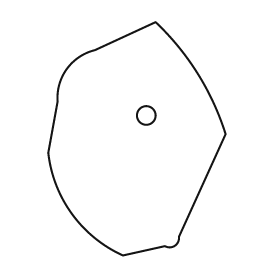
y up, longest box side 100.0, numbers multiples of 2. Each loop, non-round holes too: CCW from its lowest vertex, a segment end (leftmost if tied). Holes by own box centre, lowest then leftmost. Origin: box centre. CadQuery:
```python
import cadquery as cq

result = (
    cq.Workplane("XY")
    .moveTo(-6.0, -50.0)
    .lineTo(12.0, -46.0)
    .threePointArc((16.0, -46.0), (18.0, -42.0))
    .lineTo(38.0, 2.0)
    .threePointArc((26.0, 28.0), (8.0, 50.0))
    .lineTo(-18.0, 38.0)
    .threePointArc((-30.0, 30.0), (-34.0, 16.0))
    .lineTo(-38.0, -6.0)
    .threePointArc((-28.0, -32.0), (-6.0, -50.0))
    .close()
    .moveTo(4.0, 10.0)
    .circle(4.0)
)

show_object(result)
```